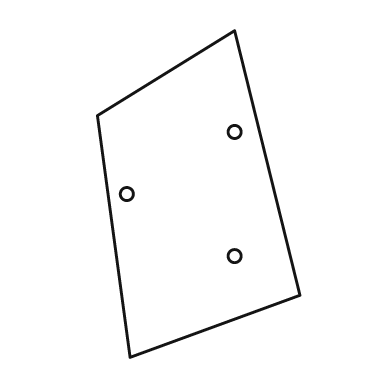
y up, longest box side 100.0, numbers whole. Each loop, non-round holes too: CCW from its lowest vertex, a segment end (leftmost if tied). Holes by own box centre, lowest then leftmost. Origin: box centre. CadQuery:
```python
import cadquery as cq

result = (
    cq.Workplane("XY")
    .moveTo(-21.0, -50.0)
    .lineTo(31.0, -31.0)
    .lineTo(11.0, 50.0)
    .lineTo(-31.0, 24.0)
    .close()
    .moveTo(11.0, -19.0)
    .circle(2.0)
    .moveTo(-22.0, 0.0)
    .circle(2.0)
    .moveTo(11.0, 19.0)
    .circle(2.0)
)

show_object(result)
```